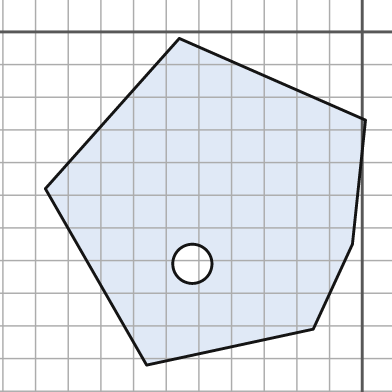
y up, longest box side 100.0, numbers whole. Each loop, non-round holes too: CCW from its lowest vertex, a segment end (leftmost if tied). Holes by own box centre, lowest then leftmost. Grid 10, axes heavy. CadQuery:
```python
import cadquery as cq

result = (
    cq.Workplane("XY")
    .moveTo(-66.0, -102.0)
    .lineTo(-15.0, -91.0)
    .lineTo(-3.0, -65.0)
    .lineTo(1.0, -27.0)
    .lineTo(-56.0, -2.0)
    .lineTo(-97.0, -48.0)
    .close()
    .moveTo(-52.0, -71.0)
    .circle(6.0)
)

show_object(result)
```